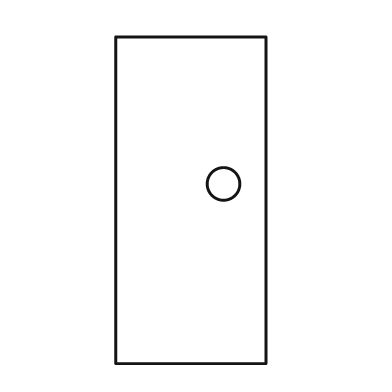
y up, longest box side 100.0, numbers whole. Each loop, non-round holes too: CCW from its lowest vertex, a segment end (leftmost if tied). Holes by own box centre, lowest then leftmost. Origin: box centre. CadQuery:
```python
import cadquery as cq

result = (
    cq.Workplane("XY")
    .moveTo(-23.0, -50.0)
    .lineTo(23.0, -50.0)
    .lineTo(23.0, 50.0)
    .lineTo(-23.0, 50.0)
    .close()
    .moveTo(10.0, 5.0)
    .circle(5.0)
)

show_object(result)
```